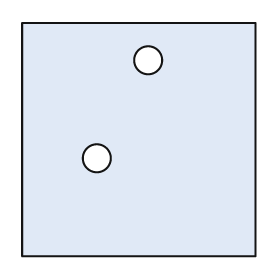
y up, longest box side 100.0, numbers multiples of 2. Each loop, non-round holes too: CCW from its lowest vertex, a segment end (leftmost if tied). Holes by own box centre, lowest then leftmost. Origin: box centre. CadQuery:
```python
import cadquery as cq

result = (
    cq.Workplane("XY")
    .moveTo(-50.0, -50.0)
    .lineTo(50.0, -50.0)
    .lineTo(50.0, 50.0)
    .lineTo(-50.0, 50.0)
    .close()
    .moveTo(-18.0, -8.0)
    .circle(6.0)
    .moveTo(4.0, 34.0)
    .circle(6.0)
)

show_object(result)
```